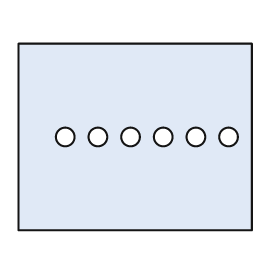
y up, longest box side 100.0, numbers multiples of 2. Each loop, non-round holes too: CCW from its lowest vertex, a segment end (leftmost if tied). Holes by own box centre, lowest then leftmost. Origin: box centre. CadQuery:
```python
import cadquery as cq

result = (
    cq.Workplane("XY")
    .moveTo(-50.0, -40.0)
    .lineTo(50.0, -40.0)
    .lineTo(50.0, 40.0)
    .lineTo(-50.0, 40.0)
    .close()
    .moveTo(-30.0, 0.0)
    .circle(4.0)
    .moveTo(-16.0, 0.0)
    .circle(4.0)
    .moveTo(-2.0, 0.0)
    .circle(4.0)
    .moveTo(12.0, 0.0)
    .circle(4.0)
    .moveTo(26.0, 0.0)
    .circle(4.0)
    .moveTo(40.0, 0.0)
    .circle(4.0)
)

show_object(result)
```